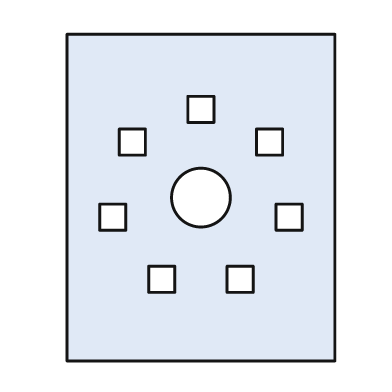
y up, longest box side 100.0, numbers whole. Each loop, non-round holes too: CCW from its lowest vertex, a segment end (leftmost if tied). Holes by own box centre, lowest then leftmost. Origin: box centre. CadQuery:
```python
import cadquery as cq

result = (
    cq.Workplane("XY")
    .moveTo(-41.0, -50.0)
    .lineTo(41.0, -50.0)
    .lineTo(41.0, 50.0)
    .lineTo(-41.0, 50.0)
    .close()
    .moveTo(-16.0, -29.0)
    .lineTo(-8.0, -29.0)
    .lineTo(-8.0, -21.0)
    .lineTo(-16.0, -21.0)
    .close()
    .moveTo(8.0, -29.0)
    .lineTo(16.0, -29.0)
    .lineTo(16.0, -21.0)
    .lineTo(8.0, -21.0)
    .close()
    .moveTo(-31.0, -10.0)
    .lineTo(-23.0, -10.0)
    .lineTo(-23.0, -2.0)
    .lineTo(-31.0, -2.0)
    .close()
    .moveTo(23.0, -10.0)
    .lineTo(31.0, -10.0)
    .lineTo(31.0, -2.0)
    .lineTo(23.0, -2.0)
    .close()
    .moveTo(0.0, 0.0)
    .circle(9.0)
    .moveTo(-25.0, 13.0)
    .lineTo(-17.0, 13.0)
    .lineTo(-17.0, 21.0)
    .lineTo(-25.0, 21.0)
    .close()
    .moveTo(17.0, 13.0)
    .lineTo(25.0, 13.0)
    .lineTo(25.0, 21.0)
    .lineTo(17.0, 21.0)
    .close()
    .moveTo(-4.0, 23.0)
    .lineTo(4.0, 23.0)
    .lineTo(4.0, 31.0)
    .lineTo(-4.0, 31.0)
    .close()
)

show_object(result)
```